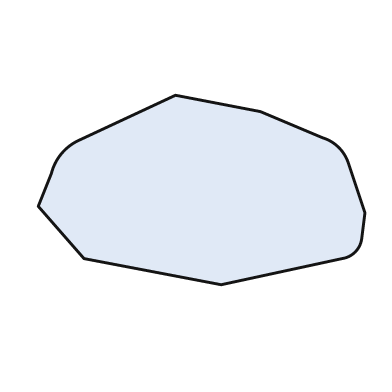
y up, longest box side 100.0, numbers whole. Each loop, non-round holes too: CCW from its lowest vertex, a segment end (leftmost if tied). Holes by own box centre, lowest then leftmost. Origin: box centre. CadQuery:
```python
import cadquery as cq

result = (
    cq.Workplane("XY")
    .moveTo(6.0, -29.0)
    .lineTo(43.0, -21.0)
    .threePointArc((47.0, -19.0), (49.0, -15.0))
    .lineTo(50.0, -7.0)
    .lineTo(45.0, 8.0)
    .threePointArc((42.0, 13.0), (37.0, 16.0))
    .lineTo(18.0, 24.0)
    .lineTo(-8.0, 29.0)
    .lineTo(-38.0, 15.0)
    .threePointArc((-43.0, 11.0), (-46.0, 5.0))
    .lineTo(-50.0, -5.0)
    .lineTo(-36.0, -21.0)
    .close()
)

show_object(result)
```